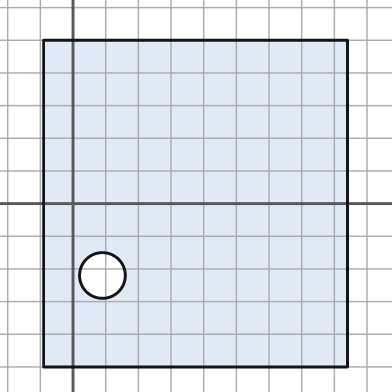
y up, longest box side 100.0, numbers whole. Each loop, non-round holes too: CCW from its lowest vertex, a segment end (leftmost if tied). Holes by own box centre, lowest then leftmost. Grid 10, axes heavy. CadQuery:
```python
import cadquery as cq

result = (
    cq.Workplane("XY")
    .moveTo(-9.0, -50.0)
    .lineTo(84.0, -50.0)
    .lineTo(84.0, 50.0)
    .lineTo(-9.0, 50.0)
    .close()
    .moveTo(9.0, -22.0)
    .circle(7.0)
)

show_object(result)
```